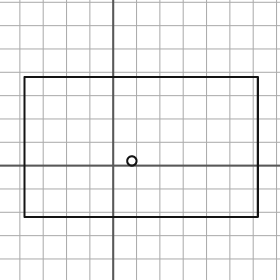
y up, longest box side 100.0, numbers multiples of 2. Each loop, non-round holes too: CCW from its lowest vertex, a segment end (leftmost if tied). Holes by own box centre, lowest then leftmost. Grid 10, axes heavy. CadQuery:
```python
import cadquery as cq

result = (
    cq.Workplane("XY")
    .moveTo(-38.0, -22.0)
    .lineTo(62.0, -22.0)
    .lineTo(62.0, 38.0)
    .lineTo(-38.0, 38.0)
    .close()
    .moveTo(8.0, 2.0)
    .circle(2.0)
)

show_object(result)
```